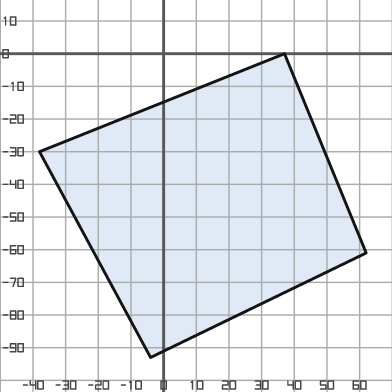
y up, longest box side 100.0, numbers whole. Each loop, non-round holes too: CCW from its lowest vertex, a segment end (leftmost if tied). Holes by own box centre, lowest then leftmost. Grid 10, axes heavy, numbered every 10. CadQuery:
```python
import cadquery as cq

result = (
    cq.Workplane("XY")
    .moveTo(-4.0, -93.0)
    .lineTo(62.0, -61.0)
    .lineTo(37.0, 0.0)
    .lineTo(-38.0, -30.0)
    .close()
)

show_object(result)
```